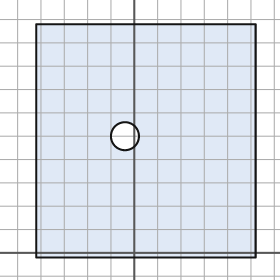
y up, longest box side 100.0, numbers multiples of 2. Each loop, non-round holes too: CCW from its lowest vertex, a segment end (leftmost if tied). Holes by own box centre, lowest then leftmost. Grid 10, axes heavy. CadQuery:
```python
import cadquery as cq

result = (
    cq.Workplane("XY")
    .moveTo(-42.0, -2.0)
    .lineTo(52.0, -2.0)
    .lineTo(52.0, 98.0)
    .lineTo(-42.0, 98.0)
    .close()
    .moveTo(-4.0, 50.0)
    .circle(6.0)
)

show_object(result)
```